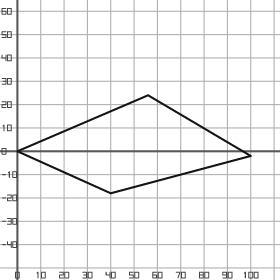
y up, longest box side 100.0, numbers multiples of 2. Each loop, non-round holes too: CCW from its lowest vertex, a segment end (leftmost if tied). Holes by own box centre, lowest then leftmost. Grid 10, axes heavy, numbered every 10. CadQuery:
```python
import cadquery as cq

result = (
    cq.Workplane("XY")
    .moveTo(40.0, -18.0)
    .lineTo(100.0, -2.0)
    .lineTo(56.0, 24.0)
    .lineTo(0.0, 0.0)
    .close()
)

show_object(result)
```